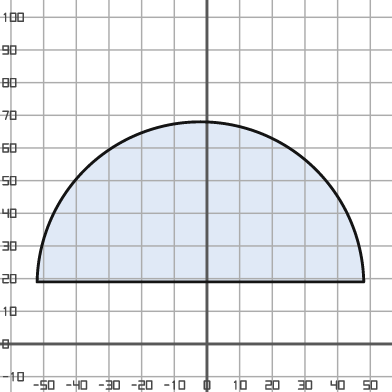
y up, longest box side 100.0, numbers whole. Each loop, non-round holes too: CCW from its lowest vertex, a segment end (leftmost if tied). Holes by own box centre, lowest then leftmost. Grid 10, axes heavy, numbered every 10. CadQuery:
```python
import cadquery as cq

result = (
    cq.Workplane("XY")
    .moveTo(-52.0, 19.0)
    .lineTo(48.0, 19.0)
    .threePointArc((-2.0, 68.0), (-52.0, 19.0))
    .close()
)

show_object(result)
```